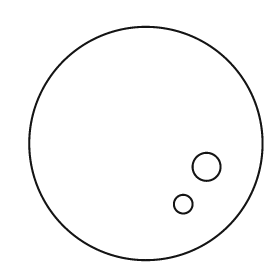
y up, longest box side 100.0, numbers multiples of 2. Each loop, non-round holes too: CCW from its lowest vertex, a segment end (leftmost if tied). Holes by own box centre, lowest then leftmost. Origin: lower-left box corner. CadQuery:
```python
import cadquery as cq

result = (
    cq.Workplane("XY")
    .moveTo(50.0, 50.0)
    .circle(50.0)
    .moveTo(66.0, 24.0)
    .circle(4.0)
    .moveTo(76.0, 40.0)
    .circle(6.0)
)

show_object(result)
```